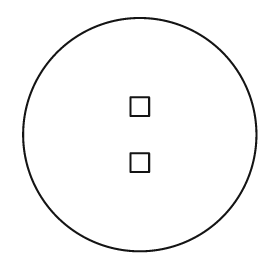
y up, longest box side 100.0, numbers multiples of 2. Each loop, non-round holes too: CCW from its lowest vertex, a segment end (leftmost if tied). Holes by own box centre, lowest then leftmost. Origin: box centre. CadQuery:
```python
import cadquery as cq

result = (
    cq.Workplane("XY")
    .moveTo(0.0, 0.0)
    .circle(50.0)
    .moveTo(-4.0, -16.0)
    .lineTo(4.0, -16.0)
    .lineTo(4.0, -8.0)
    .lineTo(-4.0, -8.0)
    .close()
    .moveTo(-4.0, 8.0)
    .lineTo(4.0, 8.0)
    .lineTo(4.0, 16.0)
    .lineTo(-4.0, 16.0)
    .close()
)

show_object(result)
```